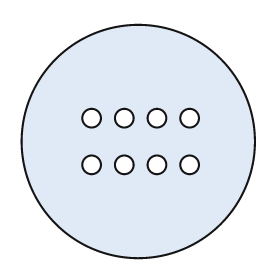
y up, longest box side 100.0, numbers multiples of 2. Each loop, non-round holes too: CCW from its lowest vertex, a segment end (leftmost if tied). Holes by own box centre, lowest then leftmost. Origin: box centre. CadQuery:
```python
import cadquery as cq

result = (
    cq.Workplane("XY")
    .moveTo(0.0, 0.0)
    .circle(50.0)
    .moveTo(-20.0, -10.0)
    .circle(4.0)
    .moveTo(-6.0, -10.0)
    .circle(4.0)
    .moveTo(8.0, -10.0)
    .circle(4.0)
    .moveTo(22.0, -10.0)
    .circle(4.0)
    .moveTo(-20.0, 10.0)
    .circle(4.0)
    .moveTo(-6.0, 10.0)
    .circle(4.0)
    .moveTo(8.0, 10.0)
    .circle(4.0)
    .moveTo(22.0, 10.0)
    .circle(4.0)
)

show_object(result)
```